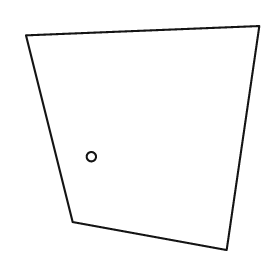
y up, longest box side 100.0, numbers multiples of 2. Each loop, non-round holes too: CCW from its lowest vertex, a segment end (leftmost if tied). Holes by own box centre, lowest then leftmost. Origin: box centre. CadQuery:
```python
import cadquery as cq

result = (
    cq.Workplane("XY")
    .moveTo(36.0, -48.0)
    .lineTo(50.0, 48.0)
    .lineTo(-50.0, 44.0)
    .lineTo(-30.0, -36.0)
    .close()
    .moveTo(-22.0, -8.0)
    .circle(2.0)
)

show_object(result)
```